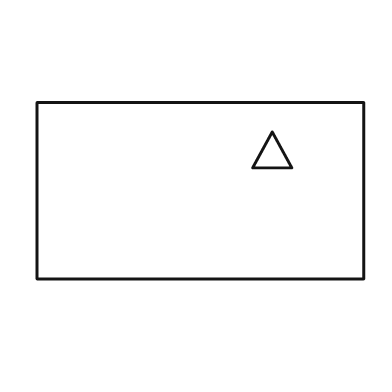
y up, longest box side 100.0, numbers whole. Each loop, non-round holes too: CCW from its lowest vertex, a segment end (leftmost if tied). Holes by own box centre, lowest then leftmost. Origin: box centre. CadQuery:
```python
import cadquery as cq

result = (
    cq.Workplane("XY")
    .moveTo(-50.0, -27.0)
    .lineTo(50.0, -27.0)
    .lineTo(50.0, 27.0)
    .lineTo(-50.0, 27.0)
    .close()
    .moveTo(16.0, 7.0)
    .lineTo(28.0, 7.0)
    .lineTo(22.0, 18.0)
    .close()
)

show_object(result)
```